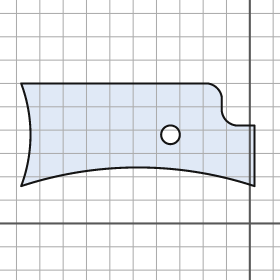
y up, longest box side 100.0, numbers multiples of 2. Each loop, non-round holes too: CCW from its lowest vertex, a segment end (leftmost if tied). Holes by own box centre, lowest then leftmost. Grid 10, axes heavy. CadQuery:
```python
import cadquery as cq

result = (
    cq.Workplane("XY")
    .moveTo(-98.0, 16.0)
    .threePointArc((-48.0, 24.0), (2.0, 16.0))
    .lineTo(2.0, 42.0)
    .lineTo(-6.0, 42.0)
    .threePointArc((-10.0, 44.0), (-12.0, 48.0))
    .lineTo(-12.0, 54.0)
    .threePointArc((-14.0, 58.0), (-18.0, 60.0))
    .lineTo(-98.0, 60.0)
    .threePointArc((-94.0, 38.0), (-98.0, 16.0))
    .close()
    .moveTo(-34.0, 38.0)
    .circle(4.0)
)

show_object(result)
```